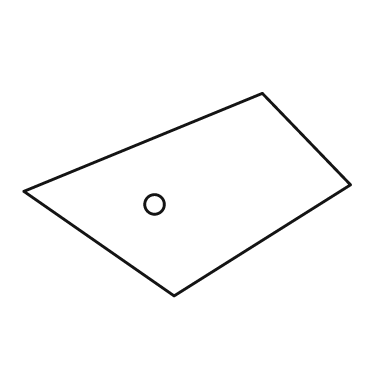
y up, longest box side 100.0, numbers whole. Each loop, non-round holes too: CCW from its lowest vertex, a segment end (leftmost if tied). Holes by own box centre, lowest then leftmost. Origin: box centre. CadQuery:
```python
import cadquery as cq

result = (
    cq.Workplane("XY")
    .moveTo(-4.0, -31.0)
    .lineTo(50.0, 3.0)
    .lineTo(23.0, 31.0)
    .lineTo(-50.0, 1.0)
    .close()
    .moveTo(-10.0, -3.0)
    .circle(3.0)
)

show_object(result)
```